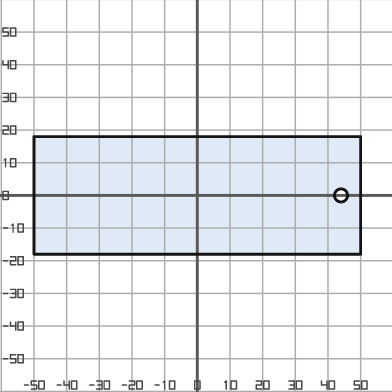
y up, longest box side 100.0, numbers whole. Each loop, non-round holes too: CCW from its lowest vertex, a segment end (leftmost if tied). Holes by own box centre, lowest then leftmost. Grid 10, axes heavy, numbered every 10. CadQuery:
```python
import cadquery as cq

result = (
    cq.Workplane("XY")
    .moveTo(-50.0, -18.0)
    .lineTo(50.0, -18.0)
    .lineTo(50.0, 18.0)
    .lineTo(-50.0, 18.0)
    .close()
    .moveTo(44.0, 0.0)
    .circle(2.0)
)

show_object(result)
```